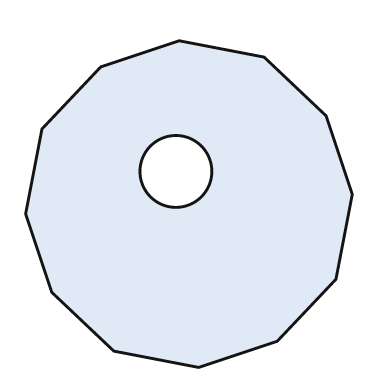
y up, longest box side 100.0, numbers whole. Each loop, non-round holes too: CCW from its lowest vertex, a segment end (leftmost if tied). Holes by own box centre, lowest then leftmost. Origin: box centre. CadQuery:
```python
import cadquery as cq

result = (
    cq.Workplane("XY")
    .moveTo(3.0, -50.0)
    .lineTo(27.0, -42.0)
    .lineTo(45.0, -23.0)
    .lineTo(50.0, 3.0)
    .lineTo(42.0, 27.0)
    .lineTo(23.0, 45.0)
    .lineTo(-3.0, 50.0)
    .lineTo(-27.0, 42.0)
    .lineTo(-45.0, 23.0)
    .lineTo(-50.0, -3.0)
    .lineTo(-42.0, -27.0)
    .lineTo(-23.0, -45.0)
    .close()
    .moveTo(-4.0, 10.0)
    .circle(11.0)
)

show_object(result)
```